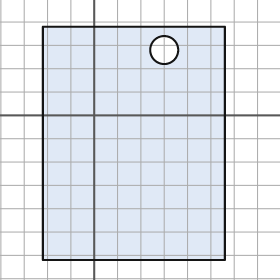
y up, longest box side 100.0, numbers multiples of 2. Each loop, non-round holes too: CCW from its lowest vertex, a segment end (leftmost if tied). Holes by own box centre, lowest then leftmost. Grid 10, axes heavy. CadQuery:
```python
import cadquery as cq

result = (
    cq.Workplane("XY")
    .moveTo(-22.0, -62.0)
    .lineTo(56.0, -62.0)
    .lineTo(56.0, 38.0)
    .lineTo(-22.0, 38.0)
    .close()
    .moveTo(30.0, 28.0)
    .circle(6.0)
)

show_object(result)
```